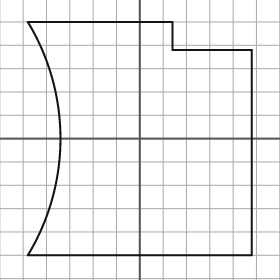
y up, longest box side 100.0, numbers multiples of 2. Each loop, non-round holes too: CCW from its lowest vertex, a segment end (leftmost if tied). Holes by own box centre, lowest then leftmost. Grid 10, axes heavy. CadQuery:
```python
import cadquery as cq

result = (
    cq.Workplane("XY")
    .moveTo(-48.0, -50.0)
    .lineTo(48.0, -50.0)
    .lineTo(48.0, 38.0)
    .lineTo(14.0, 38.0)
    .lineTo(14.0, 50.0)
    .lineTo(-48.0, 50.0)
    .threePointArc((-34.0, 0.0), (-48.0, -50.0))
    .close()
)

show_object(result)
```